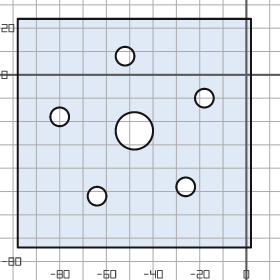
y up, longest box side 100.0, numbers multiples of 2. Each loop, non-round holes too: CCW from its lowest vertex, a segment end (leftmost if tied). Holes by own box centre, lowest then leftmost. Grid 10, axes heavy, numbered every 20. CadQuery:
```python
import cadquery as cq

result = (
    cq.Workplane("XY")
    .moveTo(-98.0, -74.0)
    .lineTo(2.0, -74.0)
    .lineTo(2.0, 24.0)
    .lineTo(-98.0, 24.0)
    .close()
    .moveTo(-64.0, -52.0)
    .circle(4.0)
    .moveTo(-26.0, -48.0)
    .circle(4.0)
    .moveTo(-48.0, -24.0)
    .circle(8.0)
    .moveTo(-80.0, -18.0)
    .circle(4.0)
    .moveTo(-18.0, -10.0)
    .circle(4.0)
    .moveTo(-52.0, 8.0)
    .circle(4.0)
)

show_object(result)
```